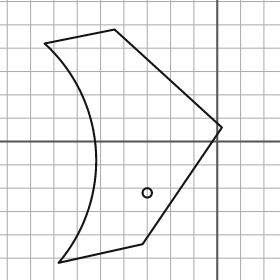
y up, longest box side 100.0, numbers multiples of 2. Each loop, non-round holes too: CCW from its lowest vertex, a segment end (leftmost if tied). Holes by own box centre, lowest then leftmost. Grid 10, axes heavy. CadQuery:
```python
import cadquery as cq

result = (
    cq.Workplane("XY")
    .moveTo(-68.0, -52.0)
    .lineTo(-32.0, -44.0)
    .lineTo(2.0, 6.0)
    .lineTo(-44.0, 48.0)
    .lineTo(-74.0, 42.0)
    .threePointArc((-52.0, -4.0), (-68.0, -52.0))
    .close()
    .moveTo(-30.0, -22.0)
    .circle(2.0)
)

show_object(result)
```